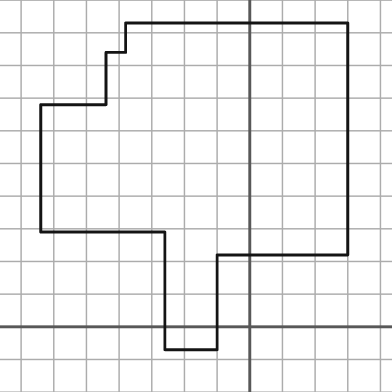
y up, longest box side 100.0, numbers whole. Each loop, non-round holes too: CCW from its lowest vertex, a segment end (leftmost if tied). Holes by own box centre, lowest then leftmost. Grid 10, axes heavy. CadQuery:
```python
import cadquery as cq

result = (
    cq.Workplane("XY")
    .moveTo(-26.0, -7.0)
    .lineTo(-10.0, -7.0)
    .lineTo(-10.0, 22.0)
    .lineTo(30.0, 22.0)
    .lineTo(30.0, 93.0)
    .lineTo(-38.0, 93.0)
    .lineTo(-38.0, 84.0)
    .lineTo(-44.0, 84.0)
    .lineTo(-44.0, 68.0)
    .lineTo(-64.0, 68.0)
    .lineTo(-64.0, 29.0)
    .lineTo(-26.0, 29.0)
    .close()
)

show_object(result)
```